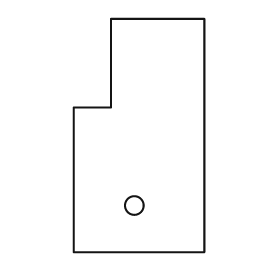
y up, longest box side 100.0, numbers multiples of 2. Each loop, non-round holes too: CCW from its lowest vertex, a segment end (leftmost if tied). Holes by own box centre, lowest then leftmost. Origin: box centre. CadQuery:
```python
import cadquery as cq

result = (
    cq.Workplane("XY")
    .moveTo(-28.0, -50.0)
    .lineTo(28.0, -50.0)
    .lineTo(28.0, 50.0)
    .lineTo(-12.0, 50.0)
    .lineTo(-12.0, 12.0)
    .lineTo(-28.0, 12.0)
    .close()
    .moveTo(-2.0, -30.0)
    .circle(4.0)
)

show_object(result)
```